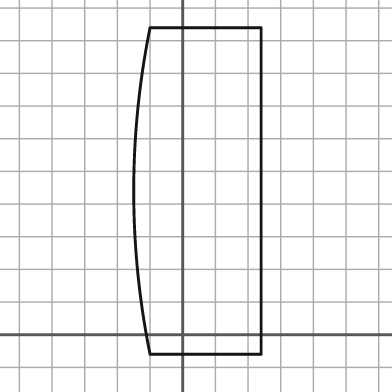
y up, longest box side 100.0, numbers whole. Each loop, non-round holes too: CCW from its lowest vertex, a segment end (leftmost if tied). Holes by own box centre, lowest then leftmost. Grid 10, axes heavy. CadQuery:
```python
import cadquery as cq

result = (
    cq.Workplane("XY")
    .moveTo(-10.0, -6.0)
    .lineTo(24.0, -6.0)
    .lineTo(24.0, 94.0)
    .lineTo(-10.0, 94.0)
    .threePointArc((-15.0, 44.0), (-10.0, -6.0))
    .close()
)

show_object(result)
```